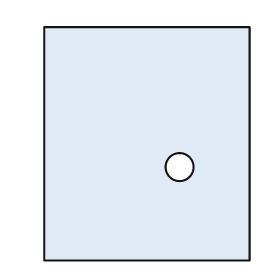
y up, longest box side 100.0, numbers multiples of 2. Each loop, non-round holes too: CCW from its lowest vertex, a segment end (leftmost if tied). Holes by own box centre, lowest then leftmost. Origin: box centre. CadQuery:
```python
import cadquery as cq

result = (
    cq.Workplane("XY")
    .moveTo(-44.0, -50.0)
    .lineTo(44.0, -50.0)
    .lineTo(44.0, 50.0)
    .lineTo(-44.0, 50.0)
    .close()
    .moveTo(14.0, -10.0)
    .circle(6.0)
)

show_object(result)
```